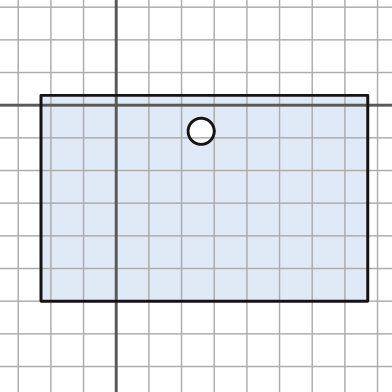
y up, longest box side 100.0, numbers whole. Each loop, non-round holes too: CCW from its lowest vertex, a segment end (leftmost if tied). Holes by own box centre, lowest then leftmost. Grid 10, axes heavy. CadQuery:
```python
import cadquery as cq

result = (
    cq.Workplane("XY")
    .moveTo(-23.0, -60.0)
    .lineTo(77.0, -60.0)
    .lineTo(77.0, 3.0)
    .lineTo(-23.0, 3.0)
    .close()
    .moveTo(26.0, -8.0)
    .circle(4.0)
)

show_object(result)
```